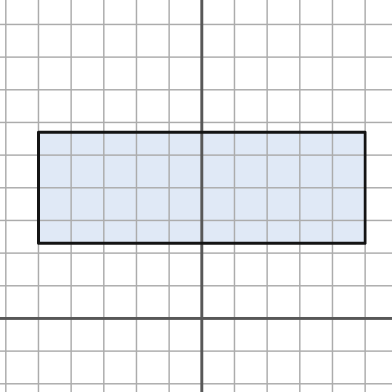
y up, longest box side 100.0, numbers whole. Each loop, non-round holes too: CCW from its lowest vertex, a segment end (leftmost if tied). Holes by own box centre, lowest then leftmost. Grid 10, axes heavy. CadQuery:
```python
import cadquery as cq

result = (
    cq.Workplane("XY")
    .moveTo(-50.0, 23.0)
    .lineTo(50.0, 23.0)
    .lineTo(50.0, 57.0)
    .lineTo(-50.0, 57.0)
    .close()
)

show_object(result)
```